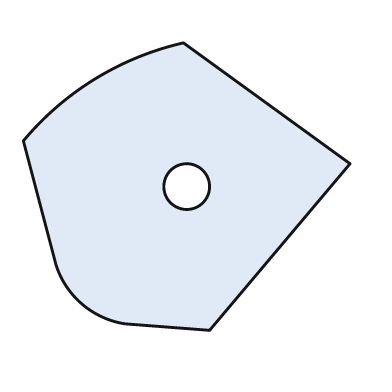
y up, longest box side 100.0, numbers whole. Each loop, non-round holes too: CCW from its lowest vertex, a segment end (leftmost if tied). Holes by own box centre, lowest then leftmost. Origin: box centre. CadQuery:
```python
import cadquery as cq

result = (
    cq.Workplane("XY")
    .moveTo(7.0, -44.0)
    .lineTo(50.0, 7.0)
    .lineTo(-1.0, 44.0)
    .threePointArc((-28.0, 33.0), (-50.0, 14.0))
    .lineTo(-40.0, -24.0)
    .threePointArc((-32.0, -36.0), (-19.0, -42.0))
    .close()
    .moveTo(0.0, 0.0)
    .circle(7.0)
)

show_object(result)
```